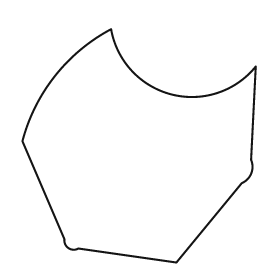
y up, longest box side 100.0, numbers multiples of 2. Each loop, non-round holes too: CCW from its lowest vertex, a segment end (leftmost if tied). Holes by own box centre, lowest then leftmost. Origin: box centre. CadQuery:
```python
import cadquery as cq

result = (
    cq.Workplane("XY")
    .moveTo(16.0, -50.0)
    .lineTo(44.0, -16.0)
    .threePointArc((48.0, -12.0), (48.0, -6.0))
    .lineTo(50.0, 34.0)
    .threePointArc((14.0, 22.0), (-12.0, 50.0))
    .threePointArc((-36.0, 30.0), (-50.0, 2.0))
    .lineTo(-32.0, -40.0)
    .threePointArc((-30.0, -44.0), (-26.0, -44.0))
    .close()
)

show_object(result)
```